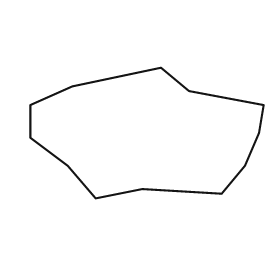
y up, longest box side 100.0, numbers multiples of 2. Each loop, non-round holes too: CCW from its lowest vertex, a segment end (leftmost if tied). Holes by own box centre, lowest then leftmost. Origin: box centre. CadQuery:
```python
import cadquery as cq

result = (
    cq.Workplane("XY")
    .moveTo(-22.0, -28.0)
    .lineTo(-2.0, -24.0)
    .lineTo(32.0, -26.0)
    .lineTo(42.0, -14.0)
    .lineTo(48.0, 0.0)
    .lineTo(50.0, 12.0)
    .lineTo(18.0, 18.0)
    .lineTo(6.0, 28.0)
    .lineTo(-32.0, 20.0)
    .lineTo(-50.0, 12.0)
    .lineTo(-50.0, -2.0)
    .lineTo(-34.0, -14.0)
    .close()
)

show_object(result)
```